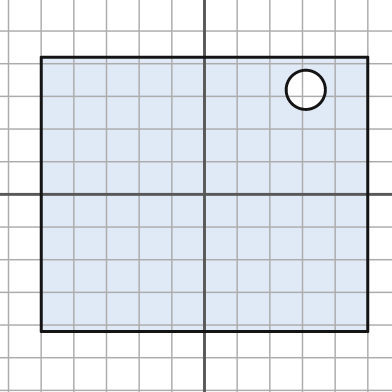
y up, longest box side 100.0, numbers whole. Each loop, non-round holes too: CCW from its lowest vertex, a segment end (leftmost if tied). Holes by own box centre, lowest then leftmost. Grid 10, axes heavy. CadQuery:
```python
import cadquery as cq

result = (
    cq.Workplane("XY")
    .moveTo(-50.0, -42.0)
    .lineTo(50.0, -42.0)
    .lineTo(50.0, 42.0)
    .lineTo(-50.0, 42.0)
    .close()
    .moveTo(31.0, 32.0)
    .circle(6.0)
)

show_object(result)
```